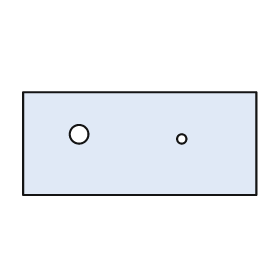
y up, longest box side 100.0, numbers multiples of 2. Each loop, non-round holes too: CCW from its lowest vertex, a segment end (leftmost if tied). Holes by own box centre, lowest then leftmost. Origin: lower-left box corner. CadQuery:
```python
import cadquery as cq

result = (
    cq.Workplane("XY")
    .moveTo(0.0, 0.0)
    .lineTo(100.0, 0.0)
    .lineTo(100.0, 44.0)
    .lineTo(0.0, 44.0)
    .close()
    .moveTo(68.0, 24.0)
    .circle(2.0)
    .moveTo(24.0, 26.0)
    .circle(4.0)
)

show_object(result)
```